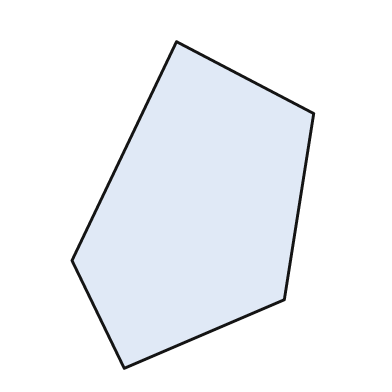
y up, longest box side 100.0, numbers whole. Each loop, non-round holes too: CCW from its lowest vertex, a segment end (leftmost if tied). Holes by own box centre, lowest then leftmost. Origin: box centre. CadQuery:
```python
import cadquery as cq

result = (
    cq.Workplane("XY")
    .moveTo(-21.0, -50.0)
    .lineTo(28.0, -29.0)
    .lineTo(37.0, 28.0)
    .lineTo(-5.0, 50.0)
    .lineTo(-37.0, -17.0)
    .close()
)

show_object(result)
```